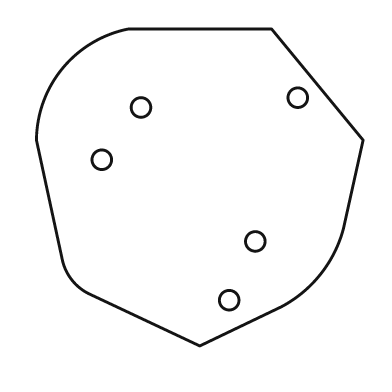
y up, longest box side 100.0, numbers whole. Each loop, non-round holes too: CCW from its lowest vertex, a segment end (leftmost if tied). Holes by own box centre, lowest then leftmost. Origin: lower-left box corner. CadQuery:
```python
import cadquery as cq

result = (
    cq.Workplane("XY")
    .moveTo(50.0, 0.0)
    .lineTo(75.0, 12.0)
    .threePointArc((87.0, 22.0), (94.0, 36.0))
    .lineTo(100.0, 63.0)
    .lineTo(72.0, 97.0)
    .lineTo(28.0, 97.0)
    .threePointArc((8.0, 85.0), (0.0, 63.0))
    .lineTo(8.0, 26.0)
    .threePointArc((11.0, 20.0), (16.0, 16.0))
    .close()
    .moveTo(59.0, 14.0)
    .circle(3.0)
    .moveTo(67.0, 32.0)
    .circle(3.0)
    .moveTo(20.0, 57.0)
    .circle(3.0)
    .moveTo(32.0, 73.0)
    .circle(3.0)
    .moveTo(80.0, 76.0)
    .circle(3.0)
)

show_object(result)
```